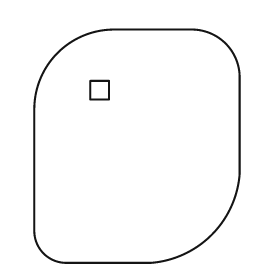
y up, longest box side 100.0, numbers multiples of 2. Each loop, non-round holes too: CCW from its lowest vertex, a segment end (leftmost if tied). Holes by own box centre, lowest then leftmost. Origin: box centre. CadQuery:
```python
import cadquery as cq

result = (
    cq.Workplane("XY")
    .moveTo(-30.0, -50.0)
    .lineTo(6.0, -50.0)
    .threePointArc((32.0, -38.0), (44.0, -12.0))
    .lineTo(44.0, 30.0)
    .threePointArc((38.0, 44.0), (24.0, 50.0))
    .lineTo(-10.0, 50.0)
    .threePointArc((-34.0, 40.0), (-44.0, 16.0))
    .lineTo(-44.0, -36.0)
    .threePointArc((-40.0, -46.0), (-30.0, -50.0))
    .close()
    .moveTo(-20.0, 20.0)
    .lineTo(-12.0, 20.0)
    .lineTo(-12.0, 28.0)
    .lineTo(-20.0, 28.0)
    .close()
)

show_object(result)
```